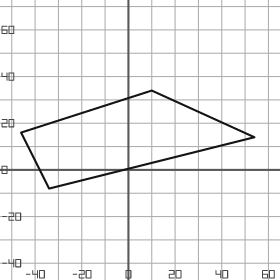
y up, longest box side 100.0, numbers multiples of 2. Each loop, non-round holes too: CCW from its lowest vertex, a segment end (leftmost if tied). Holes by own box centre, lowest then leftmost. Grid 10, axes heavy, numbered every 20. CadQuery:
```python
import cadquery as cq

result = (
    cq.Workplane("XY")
    .moveTo(-34.0, -8.0)
    .lineTo(54.0, 14.0)
    .lineTo(10.0, 34.0)
    .lineTo(-46.0, 16.0)
    .close()
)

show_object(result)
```